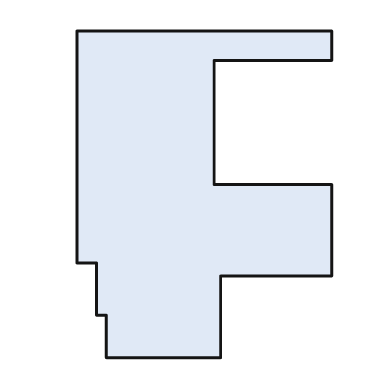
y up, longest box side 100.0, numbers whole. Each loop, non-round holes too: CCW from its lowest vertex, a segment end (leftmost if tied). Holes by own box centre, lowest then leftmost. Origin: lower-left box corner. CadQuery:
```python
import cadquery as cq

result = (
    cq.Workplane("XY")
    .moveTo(9.0, 0.0)
    .lineTo(44.0, 0.0)
    .lineTo(44.0, 25.0)
    .lineTo(78.0, 25.0)
    .lineTo(78.0, 53.0)
    .lineTo(42.0, 53.0)
    .lineTo(42.0, 91.0)
    .lineTo(78.0, 91.0)
    .lineTo(78.0, 100.0)
    .lineTo(0.0, 100.0)
    .lineTo(0.0, 29.0)
    .lineTo(6.0, 29.0)
    .lineTo(6.0, 13.0)
    .lineTo(9.0, 13.0)
    .close()
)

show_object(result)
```